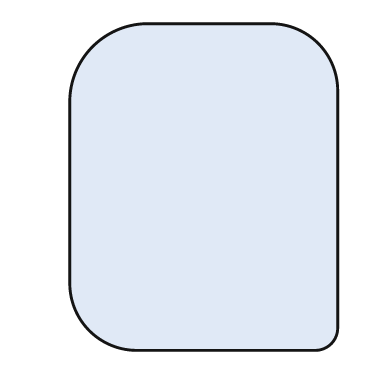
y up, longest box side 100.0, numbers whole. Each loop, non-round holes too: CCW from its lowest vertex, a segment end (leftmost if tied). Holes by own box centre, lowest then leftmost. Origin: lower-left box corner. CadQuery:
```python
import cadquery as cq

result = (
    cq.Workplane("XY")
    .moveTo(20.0, 0.0)
    .lineTo(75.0, 0.0)
    .threePointArc((80.0, 2.0), (82.0, 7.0))
    .lineTo(82.0, 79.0)
    .threePointArc((76.0, 94.0), (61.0, 100.0))
    .lineTo(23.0, 100.0)
    .threePointArc((7.0, 93.0), (0.0, 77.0))
    .lineTo(0.0, 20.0)
    .threePointArc((6.0, 6.0), (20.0, 0.0))
    .close()
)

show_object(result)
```